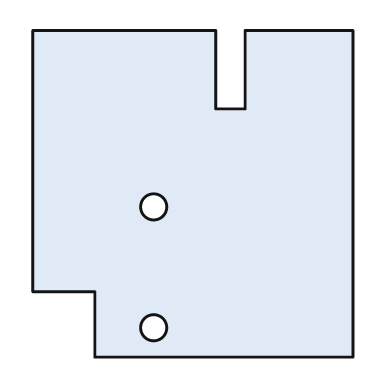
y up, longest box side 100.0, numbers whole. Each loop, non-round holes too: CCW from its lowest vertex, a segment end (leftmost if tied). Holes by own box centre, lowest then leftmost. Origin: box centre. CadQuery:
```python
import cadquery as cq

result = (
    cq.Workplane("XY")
    .moveTo(-30.0, -50.0)
    .lineTo(49.0, -50.0)
    .lineTo(49.0, 50.0)
    .lineTo(16.0, 50.0)
    .lineTo(16.0, 26.0)
    .lineTo(7.0, 26.0)
    .lineTo(7.0, 50.0)
    .lineTo(-49.0, 50.0)
    .lineTo(-49.0, -30.0)
    .lineTo(-30.0, -30.0)
    .close()
    .moveTo(-12.0, -41.0)
    .circle(4.0)
    .moveTo(-12.0, -4.0)
    .circle(4.0)
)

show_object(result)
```